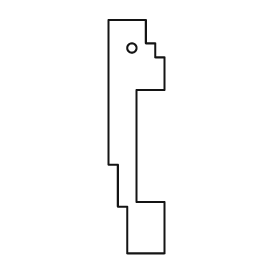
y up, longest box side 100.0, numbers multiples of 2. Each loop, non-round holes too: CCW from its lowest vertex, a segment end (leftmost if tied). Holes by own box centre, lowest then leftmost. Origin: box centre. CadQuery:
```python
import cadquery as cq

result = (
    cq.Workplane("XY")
    .moveTo(-4.0, -50.0)
    .lineTo(12.0, -50.0)
    .lineTo(12.0, -28.0)
    .lineTo(0.0, -28.0)
    .lineTo(0.0, 20.0)
    .lineTo(12.0, 20.0)
    .lineTo(12.0, 34.0)
    .lineTo(8.0, 34.0)
    .lineTo(8.0, 40.0)
    .lineTo(4.0, 40.0)
    .lineTo(4.0, 50.0)
    .lineTo(-12.0, 50.0)
    .lineTo(-12.0, -12.0)
    .lineTo(-8.0, -12.0)
    .lineTo(-8.0, -30.0)
    .lineTo(-4.0, -30.0)
    .close()
    .moveTo(-2.0, 38.0)
    .circle(2.0)
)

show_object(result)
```